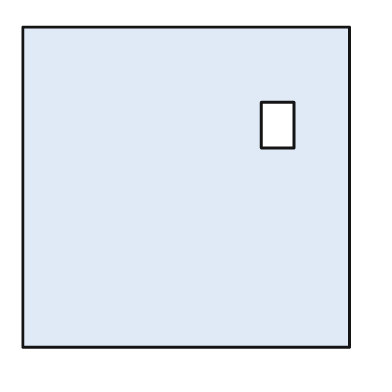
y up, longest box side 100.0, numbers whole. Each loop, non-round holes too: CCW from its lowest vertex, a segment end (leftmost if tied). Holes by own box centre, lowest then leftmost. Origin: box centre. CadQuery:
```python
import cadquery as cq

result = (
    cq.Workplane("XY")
    .moveTo(-50.0, -49.0)
    .lineTo(50.0, -49.0)
    .lineTo(50.0, 49.0)
    .lineTo(-50.0, 49.0)
    .close()
    .moveTo(23.0, 12.0)
    .lineTo(33.0, 12.0)
    .lineTo(33.0, 26.0)
    .lineTo(23.0, 26.0)
    .close()
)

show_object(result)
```